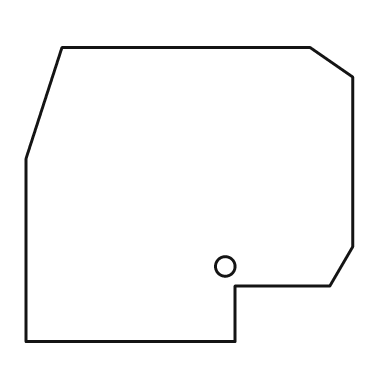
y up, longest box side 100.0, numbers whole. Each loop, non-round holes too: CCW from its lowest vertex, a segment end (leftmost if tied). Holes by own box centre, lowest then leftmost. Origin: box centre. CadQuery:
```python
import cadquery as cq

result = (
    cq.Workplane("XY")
    .moveTo(-50.0, -45.0)
    .lineTo(14.0, -45.0)
    .lineTo(14.0, -28.0)
    .lineTo(43.0, -28.0)
    .lineTo(50.0, -16.0)
    .lineTo(50.0, 36.0)
    .lineTo(37.0, 45.0)
    .lineTo(-39.0, 45.0)
    .lineTo(-50.0, 11.0)
    .close()
    .moveTo(11.0, -22.0)
    .circle(3.0)
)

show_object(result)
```